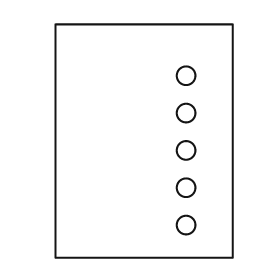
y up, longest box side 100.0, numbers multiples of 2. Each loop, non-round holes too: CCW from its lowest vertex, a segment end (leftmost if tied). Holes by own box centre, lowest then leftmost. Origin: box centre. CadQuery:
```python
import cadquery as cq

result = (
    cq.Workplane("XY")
    .moveTo(-38.0, -50.0)
    .lineTo(38.0, -50.0)
    .lineTo(38.0, 50.0)
    .lineTo(-38.0, 50.0)
    .close()
    .moveTo(18.0, -36.0)
    .circle(4.0)
    .moveTo(18.0, -20.0)
    .circle(4.0)
    .moveTo(18.0, -4.0)
    .circle(4.0)
    .moveTo(18.0, 12.0)
    .circle(4.0)
    .moveTo(18.0, 28.0)
    .circle(4.0)
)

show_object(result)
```